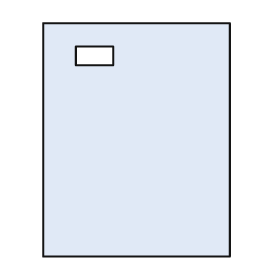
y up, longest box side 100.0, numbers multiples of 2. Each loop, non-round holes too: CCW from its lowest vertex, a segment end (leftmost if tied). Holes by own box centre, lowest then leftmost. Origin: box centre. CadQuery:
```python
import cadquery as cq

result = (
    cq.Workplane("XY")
    .moveTo(-40.0, -50.0)
    .lineTo(40.0, -50.0)
    .lineTo(40.0, 50.0)
    .lineTo(-40.0, 50.0)
    .close()
    .moveTo(-26.0, 32.0)
    .lineTo(-10.0, 32.0)
    .lineTo(-10.0, 40.0)
    .lineTo(-26.0, 40.0)
    .close()
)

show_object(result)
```